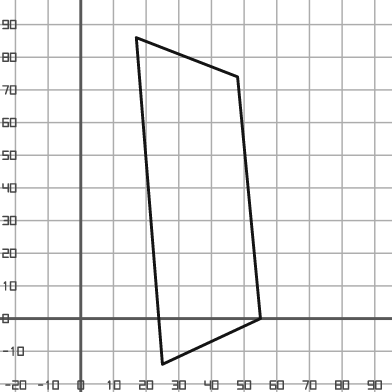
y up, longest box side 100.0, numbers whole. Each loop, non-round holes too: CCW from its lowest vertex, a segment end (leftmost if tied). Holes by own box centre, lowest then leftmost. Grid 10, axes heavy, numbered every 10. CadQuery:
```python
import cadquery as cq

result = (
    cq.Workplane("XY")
    .moveTo(25.0, -14.0)
    .lineTo(55.0, 0.0)
    .lineTo(48.0, 74.0)
    .lineTo(17.0, 86.0)
    .close()
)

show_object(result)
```